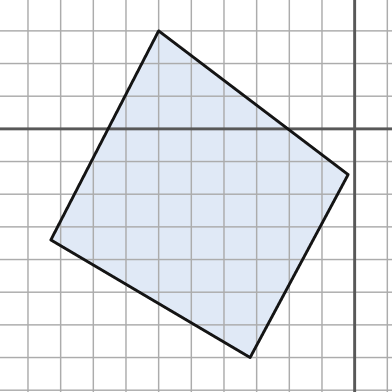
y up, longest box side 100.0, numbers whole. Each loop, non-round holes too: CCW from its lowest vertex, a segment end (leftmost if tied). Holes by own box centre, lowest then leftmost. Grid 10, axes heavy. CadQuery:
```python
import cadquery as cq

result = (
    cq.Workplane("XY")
    .moveTo(-32.0, -70.0)
    .lineTo(-2.0, -14.0)
    .lineTo(-60.0, 30.0)
    .lineTo(-93.0, -34.0)
    .close()
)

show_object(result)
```